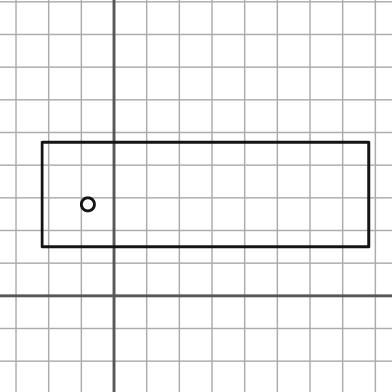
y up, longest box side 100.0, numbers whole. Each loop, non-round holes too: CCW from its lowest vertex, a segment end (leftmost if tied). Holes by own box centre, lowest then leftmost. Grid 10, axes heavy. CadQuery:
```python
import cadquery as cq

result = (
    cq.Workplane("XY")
    .moveTo(-22.0, 15.0)
    .lineTo(78.0, 15.0)
    .lineTo(78.0, 47.0)
    .lineTo(-22.0, 47.0)
    .close()
    .moveTo(-8.0, 28.0)
    .circle(2.0)
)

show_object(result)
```